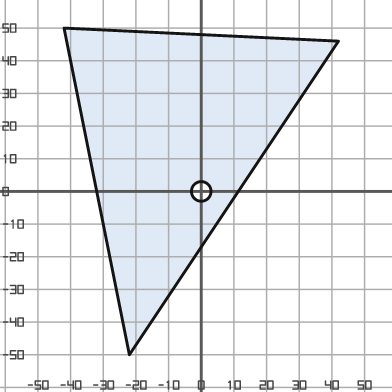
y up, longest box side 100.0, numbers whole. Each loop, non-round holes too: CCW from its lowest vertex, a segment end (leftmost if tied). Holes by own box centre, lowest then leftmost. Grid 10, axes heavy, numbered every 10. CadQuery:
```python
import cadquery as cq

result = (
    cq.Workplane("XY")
    .moveTo(-22.0, -50.0)
    .lineTo(42.0, 46.0)
    .lineTo(-42.0, 50.0)
    .close()
    .moveTo(0.0, 0.0)
    .circle(3.0)
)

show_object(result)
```